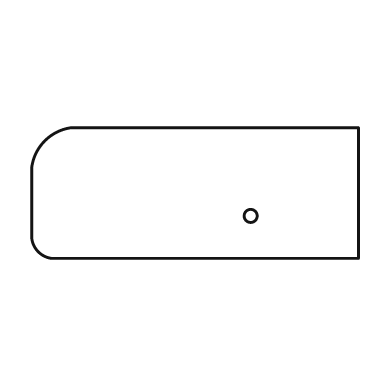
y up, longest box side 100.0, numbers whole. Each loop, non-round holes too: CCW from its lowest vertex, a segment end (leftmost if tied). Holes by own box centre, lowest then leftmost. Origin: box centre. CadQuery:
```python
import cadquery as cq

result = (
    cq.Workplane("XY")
    .moveTo(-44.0, -20.0)
    .lineTo(50.0, -20.0)
    .lineTo(50.0, 20.0)
    .lineTo(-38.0, 20.0)
    .threePointArc((-46.0, 16.0), (-50.0, 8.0))
    .lineTo(-50.0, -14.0)
    .threePointArc((-48.0, -18.0), (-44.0, -20.0))
    .close()
    .moveTo(17.0, -7.0)
    .circle(2.0)
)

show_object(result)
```